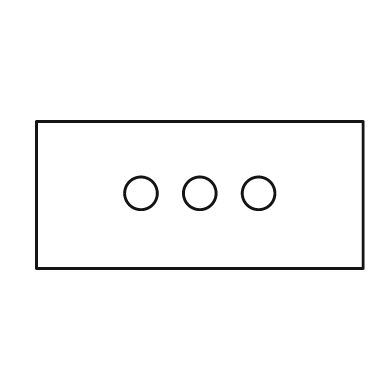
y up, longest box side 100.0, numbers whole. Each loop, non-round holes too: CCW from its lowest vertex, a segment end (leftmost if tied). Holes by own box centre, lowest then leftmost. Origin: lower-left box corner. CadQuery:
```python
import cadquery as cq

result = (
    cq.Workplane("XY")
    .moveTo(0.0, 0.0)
    .lineTo(100.0, 0.0)
    .lineTo(100.0, 45.0)
    .lineTo(0.0, 45.0)
    .close()
    .moveTo(32.0, 23.0)
    .circle(5.0)
    .moveTo(50.0, 23.0)
    .circle(5.0)
    .moveTo(68.0, 23.0)
    .circle(5.0)
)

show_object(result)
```